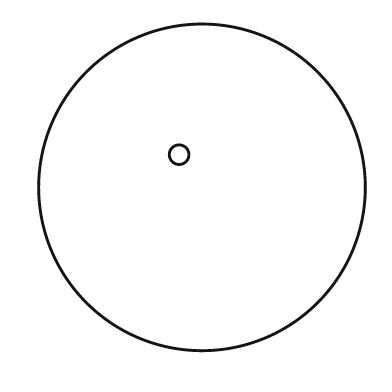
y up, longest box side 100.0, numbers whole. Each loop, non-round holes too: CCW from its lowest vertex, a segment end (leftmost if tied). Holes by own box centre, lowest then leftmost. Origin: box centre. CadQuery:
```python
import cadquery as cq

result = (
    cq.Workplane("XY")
    .moveTo(0.0, 0.0)
    .circle(50.0)
    .moveTo(-7.0, 10.0)
    .circle(3.0)
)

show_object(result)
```